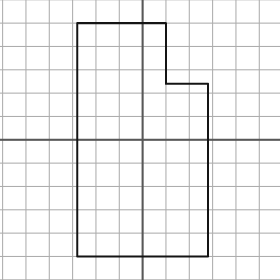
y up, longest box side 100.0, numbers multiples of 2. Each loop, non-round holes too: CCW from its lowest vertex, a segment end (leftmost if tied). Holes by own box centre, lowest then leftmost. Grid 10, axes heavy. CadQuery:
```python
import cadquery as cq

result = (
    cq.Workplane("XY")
    .moveTo(-28.0, -50.0)
    .lineTo(28.0, -50.0)
    .lineTo(28.0, 24.0)
    .lineTo(10.0, 24.0)
    .lineTo(10.0, 50.0)
    .lineTo(-28.0, 50.0)
    .close()
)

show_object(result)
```